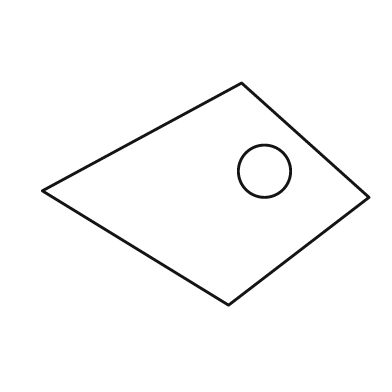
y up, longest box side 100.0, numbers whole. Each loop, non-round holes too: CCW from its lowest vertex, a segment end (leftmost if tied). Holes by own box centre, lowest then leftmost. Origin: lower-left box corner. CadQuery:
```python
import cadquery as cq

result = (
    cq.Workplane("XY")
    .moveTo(57.0, 0.0)
    .lineTo(100.0, 33.0)
    .lineTo(61.0, 68.0)
    .lineTo(0.0, 35.0)
    .close()
    .moveTo(68.0, 41.0)
    .circle(8.0)
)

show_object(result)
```